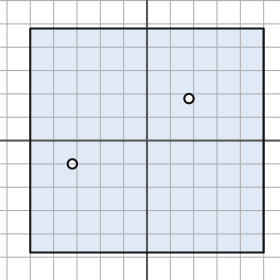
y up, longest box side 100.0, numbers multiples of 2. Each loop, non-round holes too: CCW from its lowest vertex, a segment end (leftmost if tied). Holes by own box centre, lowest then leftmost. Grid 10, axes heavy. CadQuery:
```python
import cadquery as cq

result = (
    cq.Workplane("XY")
    .moveTo(-50.0, -48.0)
    .lineTo(50.0, -48.0)
    .lineTo(50.0, 48.0)
    .lineTo(-50.0, 48.0)
    .close()
    .moveTo(-32.0, -10.0)
    .circle(2.0)
    .moveTo(18.0, 18.0)
    .circle(2.0)
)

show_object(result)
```